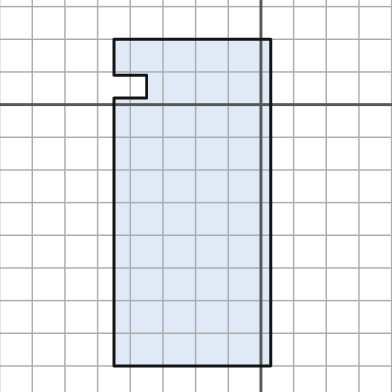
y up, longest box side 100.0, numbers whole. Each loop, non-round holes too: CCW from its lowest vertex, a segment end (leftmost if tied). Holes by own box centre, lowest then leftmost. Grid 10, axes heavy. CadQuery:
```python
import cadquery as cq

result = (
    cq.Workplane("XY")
    .moveTo(-45.0, -80.0)
    .lineTo(3.0, -80.0)
    .lineTo(3.0, 20.0)
    .lineTo(-45.0, 20.0)
    .lineTo(-45.0, 9.0)
    .lineTo(-35.0, 9.0)
    .lineTo(-35.0, 2.0)
    .lineTo(-45.0, 2.0)
    .close()
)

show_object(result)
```